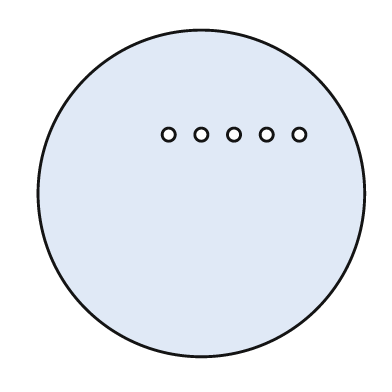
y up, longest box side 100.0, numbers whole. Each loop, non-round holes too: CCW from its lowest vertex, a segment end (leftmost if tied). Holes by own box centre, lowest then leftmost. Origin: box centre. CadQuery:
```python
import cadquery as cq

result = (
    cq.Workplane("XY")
    .moveTo(0.0, 0.0)
    .circle(50.0)
    .moveTo(-10.0, 18.0)
    .circle(2.0)
    .moveTo(0.0, 18.0)
    .circle(2.0)
    .moveTo(10.0, 18.0)
    .circle(2.0)
    .moveTo(20.0, 18.0)
    .circle(2.0)
    .moveTo(30.0, 18.0)
    .circle(2.0)
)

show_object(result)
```